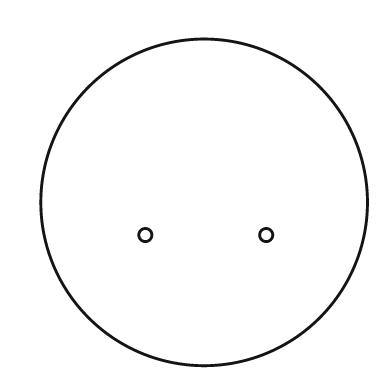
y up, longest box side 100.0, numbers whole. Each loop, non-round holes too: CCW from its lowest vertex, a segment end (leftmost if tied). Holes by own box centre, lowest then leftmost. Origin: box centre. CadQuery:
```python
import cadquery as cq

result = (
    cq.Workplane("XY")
    .moveTo(0.0, 0.0)
    .circle(50.0)
    .moveTo(-18.0, -10.0)
    .circle(2.0)
    .moveTo(19.0, -10.0)
    .circle(2.0)
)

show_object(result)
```